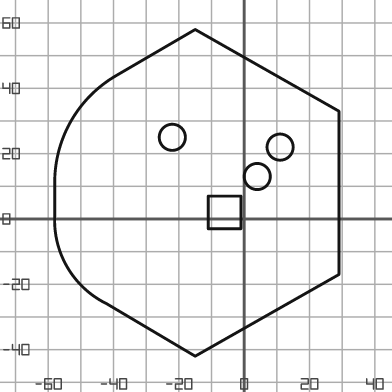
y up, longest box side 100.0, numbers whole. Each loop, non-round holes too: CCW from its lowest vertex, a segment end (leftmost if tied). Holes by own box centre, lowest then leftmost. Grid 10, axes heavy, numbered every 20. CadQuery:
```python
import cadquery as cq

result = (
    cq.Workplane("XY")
    .moveTo(-15.0, -42.0)
    .lineTo(29.0, -17.0)
    .lineTo(29.0, 33.0)
    .lineTo(-15.0, 58.0)
    .lineTo(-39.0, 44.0)
    .threePointArc((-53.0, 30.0), (-58.0, 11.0))
    .lineTo(-58.0, 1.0)
    .threePointArc((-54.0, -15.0), (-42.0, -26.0))
    .close()
    .moveTo(-11.0, -3.0)
    .lineTo(-1.0, -3.0)
    .lineTo(-1.0, 7.0)
    .lineTo(-11.0, 7.0)
    .close()
    .moveTo(4.0, 13.0)
    .circle(4.0)
    .moveTo(11.0, 22.0)
    .circle(4.0)
    .moveTo(-22.0, 25.0)
    .circle(4.0)
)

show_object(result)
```